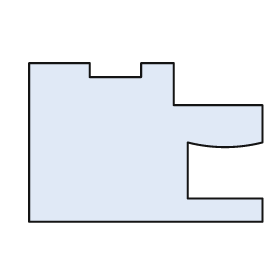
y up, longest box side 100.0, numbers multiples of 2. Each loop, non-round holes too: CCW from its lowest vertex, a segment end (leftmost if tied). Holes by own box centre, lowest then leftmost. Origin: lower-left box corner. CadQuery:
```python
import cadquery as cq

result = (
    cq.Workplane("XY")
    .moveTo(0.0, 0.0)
    .lineTo(100.0, 0.0)
    .lineTo(100.0, 10.0)
    .lineTo(68.0, 10.0)
    .lineTo(68.0, 34.0)
    .threePointArc((84.0, 32.0), (100.0, 34.0))
    .lineTo(100.0, 50.0)
    .lineTo(62.0, 50.0)
    .lineTo(62.0, 68.0)
    .lineTo(48.0, 68.0)
    .lineTo(48.0, 62.0)
    .lineTo(26.0, 62.0)
    .lineTo(26.0, 68.0)
    .lineTo(0.0, 68.0)
    .close()
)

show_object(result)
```